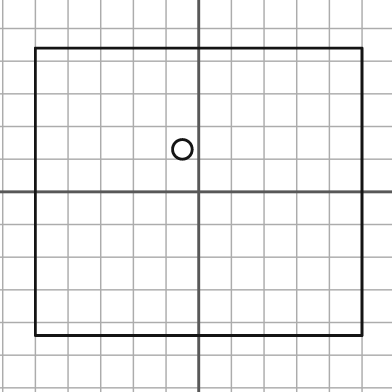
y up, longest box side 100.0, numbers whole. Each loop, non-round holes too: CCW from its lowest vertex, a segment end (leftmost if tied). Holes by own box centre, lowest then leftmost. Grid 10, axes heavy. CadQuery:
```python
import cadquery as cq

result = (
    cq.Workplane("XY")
    .moveTo(-50.0, -44.0)
    .lineTo(50.0, -44.0)
    .lineTo(50.0, 44.0)
    .lineTo(-50.0, 44.0)
    .close()
    .moveTo(-5.0, 13.0)
    .circle(3.0)
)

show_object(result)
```